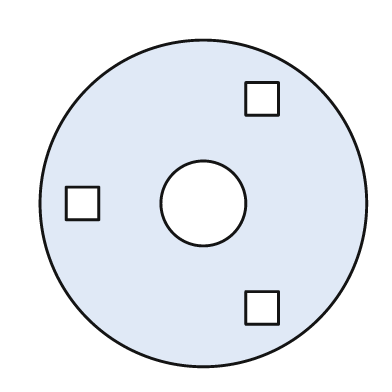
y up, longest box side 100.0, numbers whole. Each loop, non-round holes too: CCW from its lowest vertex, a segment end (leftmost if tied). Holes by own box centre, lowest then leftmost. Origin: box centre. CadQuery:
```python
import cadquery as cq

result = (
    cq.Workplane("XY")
    .moveTo(0.0, 0.0)
    .circle(50.0)
    .moveTo(13.0, -37.0)
    .lineTo(23.0, -37.0)
    .lineTo(23.0, -27.0)
    .lineTo(13.0, -27.0)
    .close()
    .moveTo(-42.0, -5.0)
    .lineTo(-32.0, -5.0)
    .lineTo(-32.0, 5.0)
    .lineTo(-42.0, 5.0)
    .close()
    .moveTo(0.0, 0.0)
    .circle(13.0)
    .moveTo(13.0, 27.0)
    .lineTo(23.0, 27.0)
    .lineTo(23.0, 37.0)
    .lineTo(13.0, 37.0)
    .close()
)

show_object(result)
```